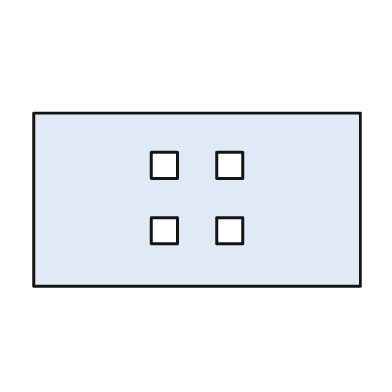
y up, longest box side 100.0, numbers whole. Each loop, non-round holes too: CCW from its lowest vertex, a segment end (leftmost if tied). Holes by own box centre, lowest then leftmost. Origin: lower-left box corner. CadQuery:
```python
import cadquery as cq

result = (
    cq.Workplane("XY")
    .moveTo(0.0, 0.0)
    .lineTo(100.0, 0.0)
    .lineTo(100.0, 53.0)
    .lineTo(0.0, 53.0)
    .close()
    .moveTo(36.0, 13.0)
    .lineTo(44.0, 13.0)
    .lineTo(44.0, 21.0)
    .lineTo(36.0, 21.0)
    .close()
    .moveTo(56.0, 13.0)
    .lineTo(64.0, 13.0)
    .lineTo(64.0, 21.0)
    .lineTo(56.0, 21.0)
    .close()
    .moveTo(36.0, 33.0)
    .lineTo(44.0, 33.0)
    .lineTo(44.0, 41.0)
    .lineTo(36.0, 41.0)
    .close()
    .moveTo(56.0, 33.0)
    .lineTo(64.0, 33.0)
    .lineTo(64.0, 41.0)
    .lineTo(56.0, 41.0)
    .close()
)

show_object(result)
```